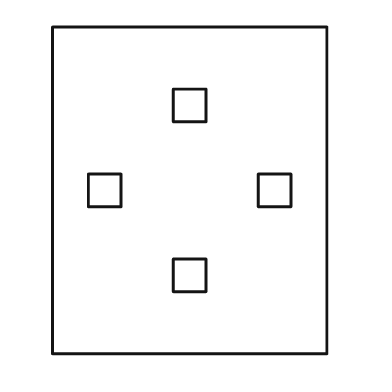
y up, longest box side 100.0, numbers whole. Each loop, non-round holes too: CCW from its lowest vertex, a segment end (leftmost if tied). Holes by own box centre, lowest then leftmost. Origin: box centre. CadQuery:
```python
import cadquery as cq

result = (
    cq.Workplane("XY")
    .moveTo(-42.0, -50.0)
    .lineTo(42.0, -50.0)
    .lineTo(42.0, 50.0)
    .lineTo(-42.0, 50.0)
    .close()
    .moveTo(-5.0, -31.0)
    .lineTo(5.0, -31.0)
    .lineTo(5.0, -21.0)
    .lineTo(-5.0, -21.0)
    .close()
    .moveTo(-31.0, -5.0)
    .lineTo(-21.0, -5.0)
    .lineTo(-21.0, 5.0)
    .lineTo(-31.0, 5.0)
    .close()
    .moveTo(21.0, -5.0)
    .lineTo(31.0, -5.0)
    .lineTo(31.0, 5.0)
    .lineTo(21.0, 5.0)
    .close()
    .moveTo(-5.0, 21.0)
    .lineTo(5.0, 21.0)
    .lineTo(5.0, 31.0)
    .lineTo(-5.0, 31.0)
    .close()
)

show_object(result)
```